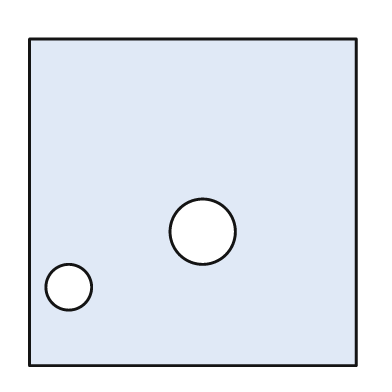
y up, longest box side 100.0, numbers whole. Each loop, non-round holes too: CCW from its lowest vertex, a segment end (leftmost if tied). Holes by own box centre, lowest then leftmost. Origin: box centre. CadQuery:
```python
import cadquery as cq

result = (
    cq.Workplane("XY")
    .moveTo(-50.0, -50.0)
    .lineTo(50.0, -50.0)
    .lineTo(50.0, 50.0)
    .lineTo(-50.0, 50.0)
    .close()
    .moveTo(-38.0, -26.0)
    .circle(7.0)
    .moveTo(3.0, -9.0)
    .circle(10.0)
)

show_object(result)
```